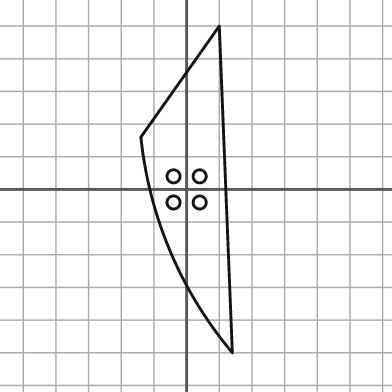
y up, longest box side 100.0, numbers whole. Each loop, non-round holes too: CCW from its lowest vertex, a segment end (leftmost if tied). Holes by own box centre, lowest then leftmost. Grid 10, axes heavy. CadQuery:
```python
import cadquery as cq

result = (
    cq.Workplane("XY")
    .moveTo(14.0, -50.0)
    .lineTo(10.0, 50.0)
    .lineTo(-14.0, 16.0)
    .threePointArc((-5.0, -19.0), (14.0, -50.0))
    .close()
    .moveTo(-4.0, -4.0)
    .circle(2.0)
    .moveTo(4.0, -4.0)
    .circle(2.0)
    .moveTo(-4.0, 4.0)
    .circle(2.0)
    .moveTo(4.0, 4.0)
    .circle(2.0)
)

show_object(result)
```